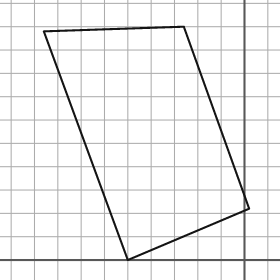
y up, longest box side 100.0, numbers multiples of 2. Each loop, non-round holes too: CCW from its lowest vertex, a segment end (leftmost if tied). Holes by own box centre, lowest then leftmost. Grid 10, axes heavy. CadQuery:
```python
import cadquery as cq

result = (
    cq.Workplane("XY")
    .moveTo(-50.0, 0.0)
    .lineTo(2.0, 22.0)
    .lineTo(-26.0, 100.0)
    .lineTo(-86.0, 98.0)
    .close()
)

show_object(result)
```